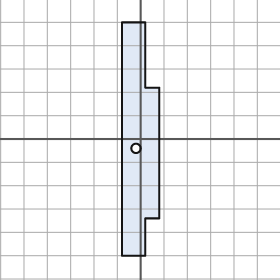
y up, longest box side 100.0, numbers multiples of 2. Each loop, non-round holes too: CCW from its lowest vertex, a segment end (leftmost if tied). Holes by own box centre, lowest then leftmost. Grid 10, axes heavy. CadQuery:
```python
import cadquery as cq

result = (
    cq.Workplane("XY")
    .moveTo(-8.0, -50.0)
    .lineTo(2.0, -50.0)
    .lineTo(2.0, -34.0)
    .lineTo(8.0, -34.0)
    .lineTo(8.0, 22.0)
    .lineTo(2.0, 22.0)
    .lineTo(2.0, 50.0)
    .lineTo(-8.0, 50.0)
    .close()
    .moveTo(-2.0, -4.0)
    .circle(2.0)
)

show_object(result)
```